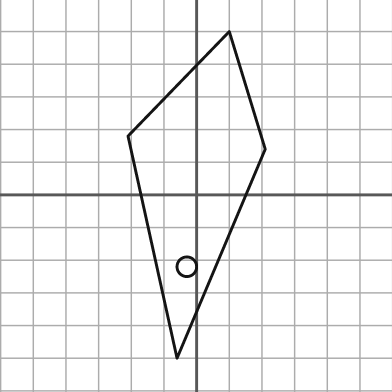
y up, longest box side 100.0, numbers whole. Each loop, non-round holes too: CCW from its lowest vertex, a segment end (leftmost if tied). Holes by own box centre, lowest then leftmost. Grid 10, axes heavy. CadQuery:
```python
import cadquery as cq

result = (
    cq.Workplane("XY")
    .moveTo(-6.0, -50.0)
    .lineTo(21.0, 14.0)
    .lineTo(10.0, 50.0)
    .lineTo(-21.0, 18.0)
    .close()
    .moveTo(-3.0, -22.0)
    .circle(3.0)
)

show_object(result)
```